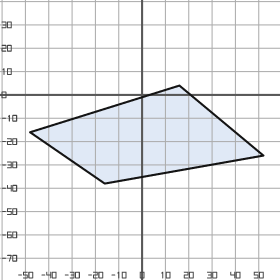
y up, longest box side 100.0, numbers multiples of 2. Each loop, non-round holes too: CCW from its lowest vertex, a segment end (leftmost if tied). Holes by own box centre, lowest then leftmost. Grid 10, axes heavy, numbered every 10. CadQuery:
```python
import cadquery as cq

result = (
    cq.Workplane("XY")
    .moveTo(-16.0, -38.0)
    .lineTo(52.0, -26.0)
    .lineTo(16.0, 4.0)
    .lineTo(-48.0, -16.0)
    .close()
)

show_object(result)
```